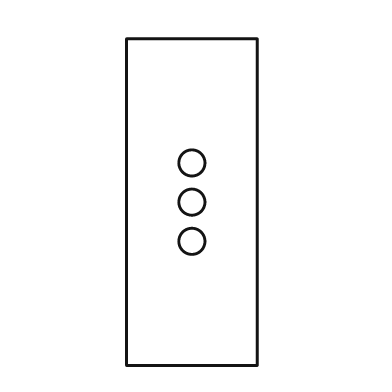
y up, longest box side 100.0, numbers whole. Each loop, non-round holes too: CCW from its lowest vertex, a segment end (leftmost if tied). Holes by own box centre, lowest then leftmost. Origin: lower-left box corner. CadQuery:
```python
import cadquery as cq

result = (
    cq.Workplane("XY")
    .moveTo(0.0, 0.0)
    .lineTo(40.0, 0.0)
    .lineTo(40.0, 100.0)
    .lineTo(0.0, 100.0)
    .close()
    .moveTo(20.0, 38.0)
    .circle(4.0)
    .moveTo(20.0, 50.0)
    .circle(4.0)
    .moveTo(20.0, 62.0)
    .circle(4.0)
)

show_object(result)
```